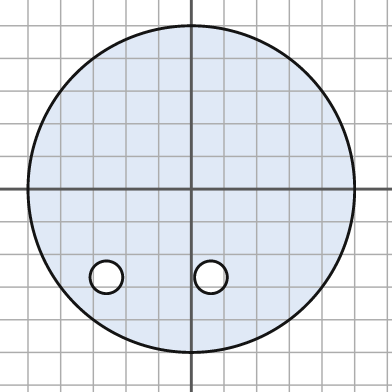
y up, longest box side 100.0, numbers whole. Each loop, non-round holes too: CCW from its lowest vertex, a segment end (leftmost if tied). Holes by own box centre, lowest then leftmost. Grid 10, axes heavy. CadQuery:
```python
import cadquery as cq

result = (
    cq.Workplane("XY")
    .moveTo(0.0, 0.0)
    .circle(50.0)
    .moveTo(-26.0, -27.0)
    .circle(5.0)
    .moveTo(6.0, -27.0)
    .circle(5.0)
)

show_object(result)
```